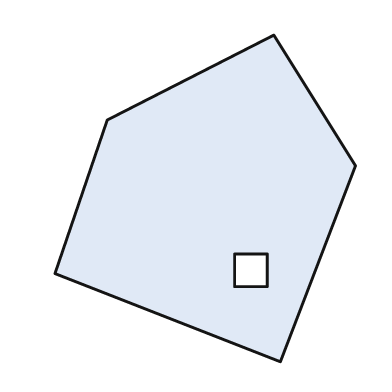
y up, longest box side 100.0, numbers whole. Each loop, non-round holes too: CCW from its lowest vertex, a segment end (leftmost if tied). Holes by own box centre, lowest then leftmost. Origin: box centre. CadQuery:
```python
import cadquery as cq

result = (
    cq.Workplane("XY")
    .moveTo(23.0, -50.0)
    .lineTo(46.0, 10.0)
    .lineTo(21.0, 50.0)
    .lineTo(-30.0, 24.0)
    .lineTo(-46.0, -23.0)
    .close()
    .moveTo(9.0, -27.0)
    .lineTo(19.0, -27.0)
    .lineTo(19.0, -17.0)
    .lineTo(9.0, -17.0)
    .close()
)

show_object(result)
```